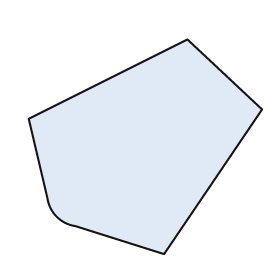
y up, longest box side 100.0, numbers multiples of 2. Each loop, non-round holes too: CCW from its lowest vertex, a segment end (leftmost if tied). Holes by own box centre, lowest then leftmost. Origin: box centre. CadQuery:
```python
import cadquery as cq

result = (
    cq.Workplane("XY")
    .moveTo(8.0, -46.0)
    .lineTo(50.0, 16.0)
    .lineTo(18.0, 46.0)
    .lineTo(-50.0, 12.0)
    .lineTo(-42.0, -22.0)
    .threePointArc((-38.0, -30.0), (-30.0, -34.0))
    .close()
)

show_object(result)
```